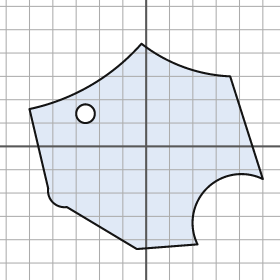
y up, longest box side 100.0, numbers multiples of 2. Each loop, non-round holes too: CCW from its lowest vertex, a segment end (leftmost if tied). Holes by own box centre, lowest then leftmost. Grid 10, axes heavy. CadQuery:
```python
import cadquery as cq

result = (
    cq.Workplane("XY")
    .moveTo(-4.0, -44.0)
    .lineTo(22.0, -42.0)
    .threePointArc((26.0, -18.0), (50.0, -14.0))
    .lineTo(36.0, 30.0)
    .threePointArc((16.0, 34.0), (-2.0, 44.0))
    .threePointArc((-24.0, 26.0), (-50.0, 16.0))
    .lineTo(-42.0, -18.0)
    .threePointArc((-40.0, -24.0), (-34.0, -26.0))
    .close()
    .moveTo(-26.0, 14.0)
    .circle(4.0)
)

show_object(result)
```